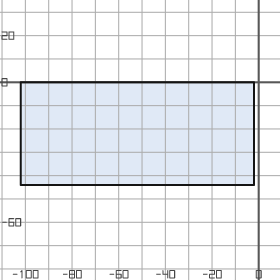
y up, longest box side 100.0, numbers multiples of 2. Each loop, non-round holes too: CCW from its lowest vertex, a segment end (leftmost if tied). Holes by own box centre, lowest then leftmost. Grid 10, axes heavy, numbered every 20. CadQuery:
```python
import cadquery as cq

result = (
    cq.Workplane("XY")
    .moveTo(-102.0, -44.0)
    .lineTo(-2.0, -44.0)
    .lineTo(-2.0, 0.0)
    .lineTo(-102.0, 0.0)
    .close()
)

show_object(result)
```